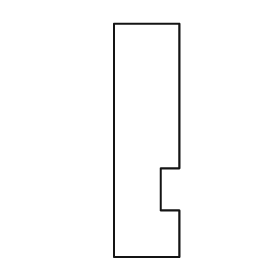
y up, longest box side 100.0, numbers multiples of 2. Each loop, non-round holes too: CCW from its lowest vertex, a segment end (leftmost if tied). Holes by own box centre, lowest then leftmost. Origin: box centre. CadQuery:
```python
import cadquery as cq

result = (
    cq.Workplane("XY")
    .moveTo(-14.0, -50.0)
    .lineTo(14.0, -50.0)
    .lineTo(14.0, -30.0)
    .lineTo(6.0, -30.0)
    .lineTo(6.0, -12.0)
    .lineTo(14.0, -12.0)
    .lineTo(14.0, 50.0)
    .lineTo(-14.0, 50.0)
    .close()
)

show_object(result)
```